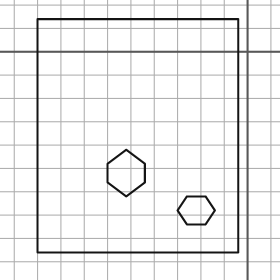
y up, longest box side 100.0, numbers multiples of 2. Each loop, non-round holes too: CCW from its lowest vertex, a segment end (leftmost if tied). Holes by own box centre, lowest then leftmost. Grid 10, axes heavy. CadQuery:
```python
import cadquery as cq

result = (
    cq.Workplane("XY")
    .moveTo(-90.0, -86.0)
    .lineTo(-4.0, -86.0)
    .lineTo(-4.0, 14.0)
    .lineTo(-90.0, 14.0)
    .close()
    .moveTo(-26.0, -74.0)
    .lineTo(-18.0, -74.0)
    .lineTo(-14.0, -68.0)
    .lineTo(-18.0, -62.0)
    .lineTo(-26.0, -62.0)
    .lineTo(-30.0, -68.0)
    .close()
    .moveTo(-52.0, -62.0)
    .lineTo(-44.0, -56.0)
    .lineTo(-44.0, -48.0)
    .lineTo(-52.0, -42.0)
    .lineTo(-60.0, -48.0)
    .lineTo(-60.0, -56.0)
    .close()
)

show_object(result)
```